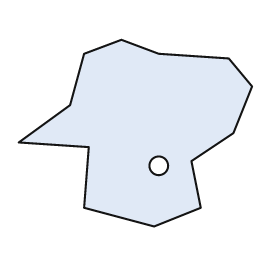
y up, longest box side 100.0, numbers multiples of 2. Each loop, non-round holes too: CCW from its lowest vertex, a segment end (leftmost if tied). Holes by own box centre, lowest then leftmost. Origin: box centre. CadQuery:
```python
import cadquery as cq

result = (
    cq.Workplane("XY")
    .moveTo(8.0, -40.0)
    .lineTo(28.0, -32.0)
    .lineTo(24.0, -12.0)
    .lineTo(42.0, 0.0)
    .lineTo(50.0, 20.0)
    .lineTo(40.0, 32.0)
    .lineTo(10.0, 34.0)
    .lineTo(-6.0, 40.0)
    .lineTo(-22.0, 34.0)
    .lineTo(-28.0, 12.0)
    .lineTo(-50.0, -4.0)
    .lineTo(-20.0, -6.0)
    .lineTo(-22.0, -32.0)
    .close()
    .moveTo(10.0, -14.0)
    .circle(4.0)
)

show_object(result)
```